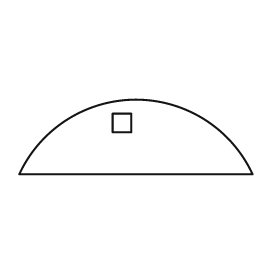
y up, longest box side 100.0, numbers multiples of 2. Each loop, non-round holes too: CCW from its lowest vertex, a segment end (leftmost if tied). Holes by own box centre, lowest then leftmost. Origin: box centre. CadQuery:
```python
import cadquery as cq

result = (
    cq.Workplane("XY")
    .moveTo(-50.0, -16.0)
    .lineTo(50.0, -16.0)
    .threePointArc((0.0, 16.0), (-50.0, -16.0))
    .close()
    .moveTo(-10.0, 2.0)
    .lineTo(-2.0, 2.0)
    .lineTo(-2.0, 10.0)
    .lineTo(-10.0, 10.0)
    .close()
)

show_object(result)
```